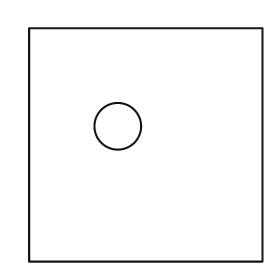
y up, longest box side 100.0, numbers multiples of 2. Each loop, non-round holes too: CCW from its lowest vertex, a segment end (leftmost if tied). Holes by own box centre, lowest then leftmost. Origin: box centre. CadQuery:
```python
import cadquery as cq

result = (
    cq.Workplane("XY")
    .moveTo(-50.0, -50.0)
    .lineTo(50.0, -50.0)
    .lineTo(50.0, 50.0)
    .lineTo(-50.0, 50.0)
    .close()
    .moveTo(-12.0, 8.0)
    .circle(10.0)
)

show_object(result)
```